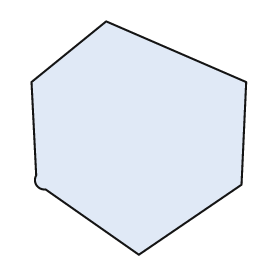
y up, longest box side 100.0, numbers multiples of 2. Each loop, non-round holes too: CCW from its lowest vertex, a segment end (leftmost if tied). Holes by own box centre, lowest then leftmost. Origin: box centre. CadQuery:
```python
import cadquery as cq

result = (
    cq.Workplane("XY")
    .moveTo(0.0, -50.0)
    .lineTo(44.0, -20.0)
    .lineTo(46.0, 24.0)
    .lineTo(-14.0, 50.0)
    .lineTo(-46.0, 24.0)
    .lineTo(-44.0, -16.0)
    .threePointArc((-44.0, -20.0), (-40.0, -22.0))
    .close()
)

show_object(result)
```